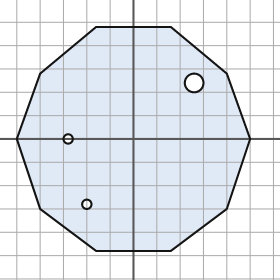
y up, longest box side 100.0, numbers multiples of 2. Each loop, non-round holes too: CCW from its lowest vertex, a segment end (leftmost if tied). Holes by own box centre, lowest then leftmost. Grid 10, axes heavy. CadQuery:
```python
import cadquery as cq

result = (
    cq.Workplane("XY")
    .moveTo(-16.0, -48.0)
    .lineTo(16.0, -48.0)
    .lineTo(40.0, -30.0)
    .lineTo(50.0, 0.0)
    .lineTo(40.0, 28.0)
    .lineTo(16.0, 48.0)
    .lineTo(-16.0, 48.0)
    .lineTo(-40.0, 28.0)
    .lineTo(-50.0, 0.0)
    .lineTo(-40.0, -30.0)
    .close()
    .moveTo(-20.0, -28.0)
    .circle(2.0)
    .moveTo(-28.0, 0.0)
    .circle(2.0)
    .moveTo(26.0, 24.0)
    .circle(4.0)
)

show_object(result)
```